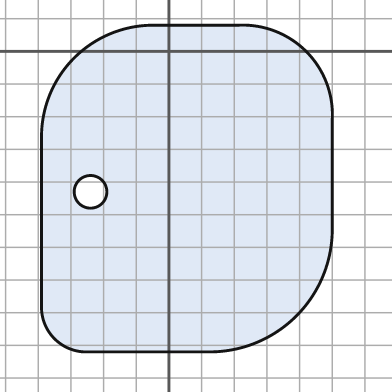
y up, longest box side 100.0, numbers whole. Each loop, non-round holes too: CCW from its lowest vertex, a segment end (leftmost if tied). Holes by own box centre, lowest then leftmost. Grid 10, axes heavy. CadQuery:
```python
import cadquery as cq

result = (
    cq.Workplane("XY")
    .moveTo(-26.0, -92.0)
    .lineTo(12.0, -92.0)
    .threePointArc((39.0, -81.0), (50.0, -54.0))
    .lineTo(50.0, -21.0)
    .threePointArc((42.0, 0.0), (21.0, 8.0))
    .lineTo(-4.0, 8.0)
    .threePointArc((-29.0, -2.0), (-39.0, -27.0))
    .lineTo(-39.0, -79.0)
    .threePointArc((-35.0, -88.0), (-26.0, -92.0))
    .close()
    .moveTo(-24.0, -43.0)
    .circle(5.0)
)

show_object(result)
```